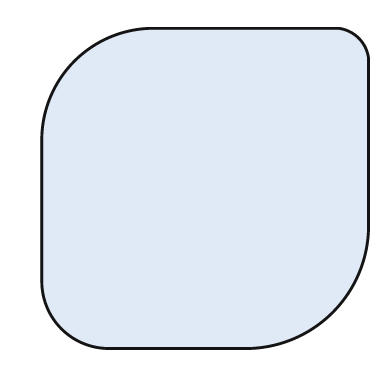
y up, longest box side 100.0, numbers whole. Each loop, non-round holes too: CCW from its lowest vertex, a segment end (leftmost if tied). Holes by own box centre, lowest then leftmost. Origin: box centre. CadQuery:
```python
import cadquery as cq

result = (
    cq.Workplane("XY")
    .moveTo(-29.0, -49.0)
    .lineTo(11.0, -49.0)
    .threePointArc((39.0, -38.0), (50.0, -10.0))
    .lineTo(50.0, 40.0)
    .threePointArc((47.0, 46.0), (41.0, 49.0))
    .lineTo(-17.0, 49.0)
    .threePointArc((-40.0, 39.0), (-50.0, 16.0))
    .lineTo(-50.0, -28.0)
    .threePointArc((-44.0, -43.0), (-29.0, -49.0))
    .close()
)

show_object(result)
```